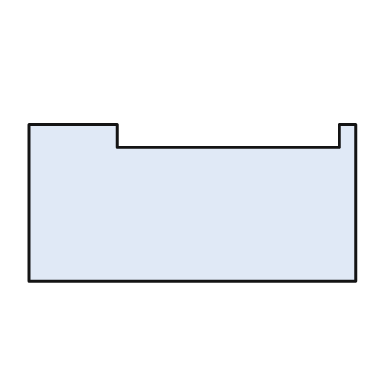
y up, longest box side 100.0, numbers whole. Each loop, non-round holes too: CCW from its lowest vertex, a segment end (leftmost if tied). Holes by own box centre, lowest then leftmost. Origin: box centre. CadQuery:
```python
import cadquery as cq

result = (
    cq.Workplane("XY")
    .moveTo(-50.0, -24.0)
    .lineTo(50.0, -24.0)
    .lineTo(50.0, 24.0)
    .lineTo(45.0, 24.0)
    .lineTo(45.0, 17.0)
    .lineTo(-23.0, 17.0)
    .lineTo(-23.0, 24.0)
    .lineTo(-50.0, 24.0)
    .close()
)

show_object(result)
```